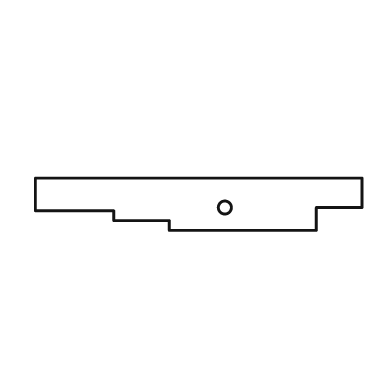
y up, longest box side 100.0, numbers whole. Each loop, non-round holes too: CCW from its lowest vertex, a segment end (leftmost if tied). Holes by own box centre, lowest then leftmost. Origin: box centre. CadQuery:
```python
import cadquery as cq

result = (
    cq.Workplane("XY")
    .moveTo(-9.0, -8.0)
    .lineTo(36.0, -8.0)
    .lineTo(36.0, -1.0)
    .lineTo(50.0, -1.0)
    .lineTo(50.0, 8.0)
    .lineTo(-50.0, 8.0)
    .lineTo(-50.0, -2.0)
    .lineTo(-26.0, -2.0)
    .lineTo(-26.0, -5.0)
    .lineTo(-9.0, -5.0)
    .close()
    .moveTo(8.0, -1.0)
    .circle(2.0)
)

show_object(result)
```